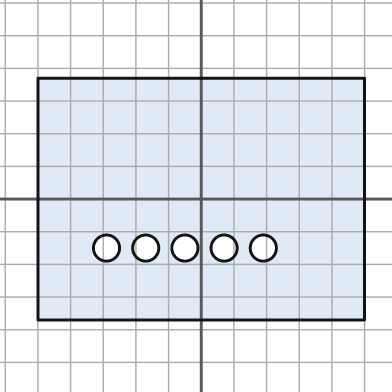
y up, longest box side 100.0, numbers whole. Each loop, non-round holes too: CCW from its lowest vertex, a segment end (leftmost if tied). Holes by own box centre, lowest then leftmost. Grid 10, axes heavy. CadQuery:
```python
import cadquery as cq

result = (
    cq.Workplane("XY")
    .moveTo(-50.0, -37.0)
    .lineTo(50.0, -37.0)
    .lineTo(50.0, 37.0)
    .lineTo(-50.0, 37.0)
    .close()
    .moveTo(-29.0, -15.0)
    .circle(4.0)
    .moveTo(-17.0, -15.0)
    .circle(4.0)
    .moveTo(-5.0, -15.0)
    .circle(4.0)
    .moveTo(7.0, -15.0)
    .circle(4.0)
    .moveTo(19.0, -15.0)
    .circle(4.0)
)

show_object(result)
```